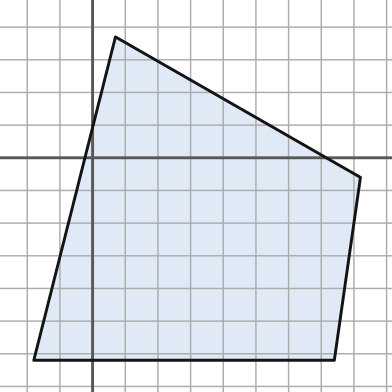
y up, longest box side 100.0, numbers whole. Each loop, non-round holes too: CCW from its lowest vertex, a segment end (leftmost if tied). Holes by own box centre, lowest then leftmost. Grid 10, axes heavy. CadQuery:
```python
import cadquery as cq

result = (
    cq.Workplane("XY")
    .moveTo(-18.0, -62.0)
    .lineTo(74.0, -62.0)
    .lineTo(82.0, -6.0)
    .lineTo(7.0, 37.0)
    .close()
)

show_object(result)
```